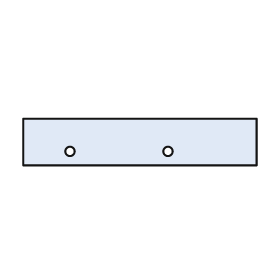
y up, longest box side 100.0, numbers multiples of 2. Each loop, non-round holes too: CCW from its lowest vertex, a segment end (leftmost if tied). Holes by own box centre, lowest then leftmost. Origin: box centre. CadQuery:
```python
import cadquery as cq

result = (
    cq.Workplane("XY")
    .moveTo(-50.0, -10.0)
    .lineTo(50.0, -10.0)
    .lineTo(50.0, 10.0)
    .lineTo(-50.0, 10.0)
    .close()
    .moveTo(-30.0, -4.0)
    .circle(2.0)
    .moveTo(12.0, -4.0)
    .circle(2.0)
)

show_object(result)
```